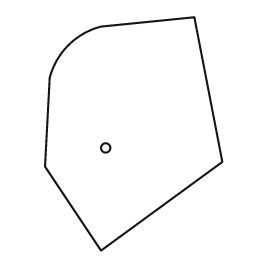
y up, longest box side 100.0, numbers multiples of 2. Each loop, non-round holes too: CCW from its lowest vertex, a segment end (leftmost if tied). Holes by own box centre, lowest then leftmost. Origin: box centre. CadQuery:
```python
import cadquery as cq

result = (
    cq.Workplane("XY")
    .moveTo(-14.0, -50.0)
    .lineTo(38.0, -12.0)
    .lineTo(26.0, 50.0)
    .lineTo(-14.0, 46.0)
    .threePointArc((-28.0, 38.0), (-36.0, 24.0))
    .lineTo(-38.0, -14.0)
    .close()
    .moveTo(-12.0, -6.0)
    .circle(2.0)
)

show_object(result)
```